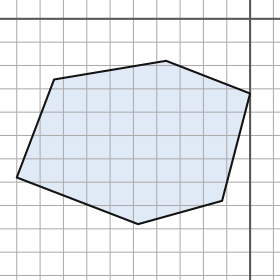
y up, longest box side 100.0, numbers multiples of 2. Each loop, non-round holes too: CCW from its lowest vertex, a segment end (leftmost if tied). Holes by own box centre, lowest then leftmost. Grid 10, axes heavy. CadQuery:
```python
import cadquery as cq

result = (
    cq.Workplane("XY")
    .moveTo(-48.0, -88.0)
    .lineTo(-12.0, -78.0)
    .lineTo(0.0, -32.0)
    .lineTo(-36.0, -18.0)
    .lineTo(-84.0, -26.0)
    .lineTo(-100.0, -68.0)
    .close()
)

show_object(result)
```